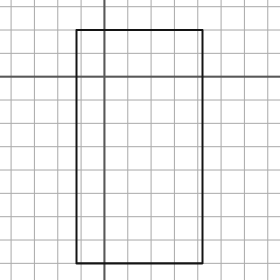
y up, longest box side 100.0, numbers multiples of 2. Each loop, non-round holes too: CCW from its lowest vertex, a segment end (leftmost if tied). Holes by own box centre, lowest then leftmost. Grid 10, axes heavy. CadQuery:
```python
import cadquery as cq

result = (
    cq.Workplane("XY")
    .moveTo(-12.0, -80.0)
    .lineTo(42.0, -80.0)
    .lineTo(42.0, 20.0)
    .lineTo(-12.0, 20.0)
    .close()
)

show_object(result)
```